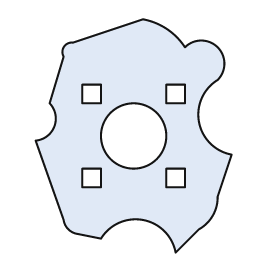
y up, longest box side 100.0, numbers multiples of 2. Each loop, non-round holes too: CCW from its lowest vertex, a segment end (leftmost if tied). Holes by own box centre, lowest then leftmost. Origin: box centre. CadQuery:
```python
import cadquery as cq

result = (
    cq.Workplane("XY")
    .moveTo(18.0, -50.0)
    .lineTo(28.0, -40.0)
    .threePointArc((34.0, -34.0), (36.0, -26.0))
    .lineTo(42.0, -8.0)
    .threePointArc((28.0, 6.0), (36.0, 24.0))
    .threePointArc((36.0, 38.0), (22.0, 38.0))
    .threePointArc((14.0, 46.0), (4.0, 50.0))
    .lineTo(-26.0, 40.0)
    .threePointArc((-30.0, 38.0), (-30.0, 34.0))
    .lineTo(-36.0, 14.0)
    .threePointArc((-34.0, 4.0), (-42.0, -2.0))
    .lineTo(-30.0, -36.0)
    .threePointArc((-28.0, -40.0), (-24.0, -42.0))
    .lineTo(-14.0, -44.0)
    .threePointArc((4.0, -36.0), (18.0, -50.0))
    .close()
    .moveTo(-22.0, -22.0)
    .lineTo(-14.0, -22.0)
    .lineTo(-14.0, -14.0)
    .lineTo(-22.0, -14.0)
    .close()
    .moveTo(14.0, -22.0)
    .lineTo(22.0, -22.0)
    .lineTo(22.0, -14.0)
    .lineTo(14.0, -14.0)
    .close()
    .moveTo(0.0, 0.0)
    .circle(14.0)
    .moveTo(-22.0, 14.0)
    .lineTo(-14.0, 14.0)
    .lineTo(-14.0, 22.0)
    .lineTo(-22.0, 22.0)
    .close()
    .moveTo(14.0, 14.0)
    .lineTo(22.0, 14.0)
    .lineTo(22.0, 22.0)
    .lineTo(14.0, 22.0)
    .close()
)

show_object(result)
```